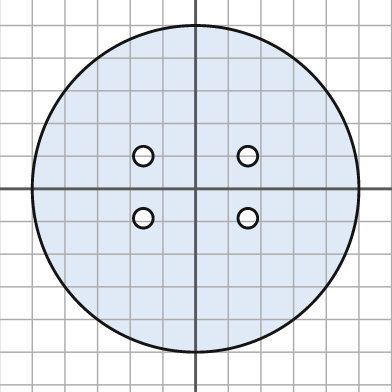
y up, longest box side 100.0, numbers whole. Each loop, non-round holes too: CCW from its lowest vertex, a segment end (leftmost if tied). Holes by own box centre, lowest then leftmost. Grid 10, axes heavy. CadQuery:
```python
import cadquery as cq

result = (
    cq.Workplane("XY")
    .moveTo(0.0, 0.0)
    .circle(50.0)
    .moveTo(-16.0, -9.0)
    .circle(3.0)
    .moveTo(16.0, -9.0)
    .circle(3.0)
    .moveTo(-16.0, 10.0)
    .circle(3.0)
    .moveTo(16.0, 10.0)
    .circle(3.0)
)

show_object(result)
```